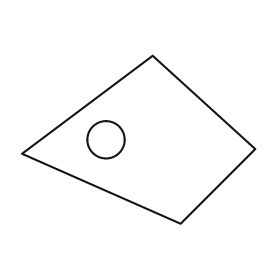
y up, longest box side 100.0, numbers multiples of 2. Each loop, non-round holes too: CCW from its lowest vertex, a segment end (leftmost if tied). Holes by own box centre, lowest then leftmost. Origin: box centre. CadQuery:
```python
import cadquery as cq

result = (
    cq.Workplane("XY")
    .moveTo(18.0, -36.0)
    .lineTo(50.0, -4.0)
    .lineTo(6.0, 36.0)
    .lineTo(-50.0, -6.0)
    .close()
    .moveTo(-14.0, 0.0)
    .circle(8.0)
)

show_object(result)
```